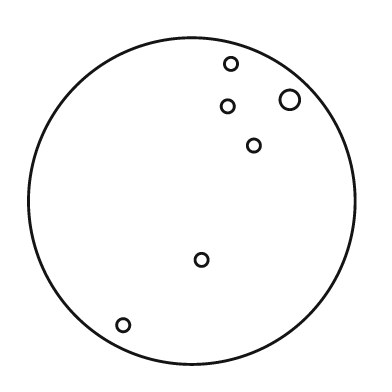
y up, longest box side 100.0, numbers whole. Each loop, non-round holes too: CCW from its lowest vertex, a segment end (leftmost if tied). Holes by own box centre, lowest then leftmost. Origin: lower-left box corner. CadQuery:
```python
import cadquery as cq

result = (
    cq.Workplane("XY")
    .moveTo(50.0, 50.0)
    .circle(50.0)
    .moveTo(29.0, 12.0)
    .circle(2.0)
    .moveTo(53.0, 32.0)
    .circle(2.0)
    .moveTo(69.0, 67.0)
    .circle(2.0)
    .moveTo(61.0, 79.0)
    .circle(2.0)
    .moveTo(80.0, 81.0)
    .circle(3.0)
    .moveTo(62.0, 92.0)
    .circle(2.0)
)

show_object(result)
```